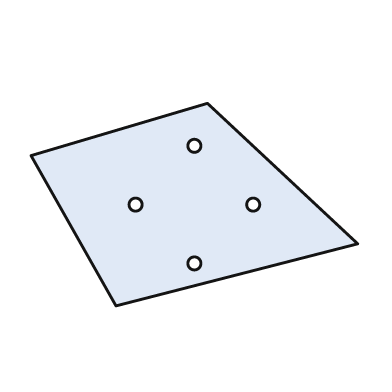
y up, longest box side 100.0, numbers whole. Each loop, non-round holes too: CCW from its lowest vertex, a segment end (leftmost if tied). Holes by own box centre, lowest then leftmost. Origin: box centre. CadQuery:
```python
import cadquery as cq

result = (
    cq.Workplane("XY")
    .moveTo(-24.0, -31.0)
    .lineTo(50.0, -12.0)
    .lineTo(4.0, 31.0)
    .lineTo(-50.0, 15.0)
    .close()
    .moveTo(0.0, -18.0)
    .circle(2.0)
    .moveTo(-18.0, 0.0)
    .circle(2.0)
    .moveTo(18.0, 0.0)
    .circle(2.0)
    .moveTo(0.0, 18.0)
    .circle(2.0)
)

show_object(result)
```